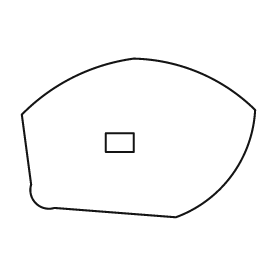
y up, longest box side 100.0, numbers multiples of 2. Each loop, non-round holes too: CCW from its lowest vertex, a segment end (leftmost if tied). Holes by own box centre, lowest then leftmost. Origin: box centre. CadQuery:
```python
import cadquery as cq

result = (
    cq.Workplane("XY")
    .moveTo(16.0, -34.0)
    .threePointArc((40.0, -16.0), (50.0, 12.0))
    .threePointArc((26.0, 28.0), (-2.0, 34.0))
    .threePointArc((-28.0, 26.0), (-50.0, 10.0))
    .lineTo(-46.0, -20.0)
    .threePointArc((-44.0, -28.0), (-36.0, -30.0))
    .close()
    .moveTo(-14.0, -6.0)
    .lineTo(-2.0, -6.0)
    .lineTo(-2.0, 2.0)
    .lineTo(-14.0, 2.0)
    .close()
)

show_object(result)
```